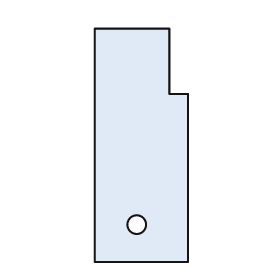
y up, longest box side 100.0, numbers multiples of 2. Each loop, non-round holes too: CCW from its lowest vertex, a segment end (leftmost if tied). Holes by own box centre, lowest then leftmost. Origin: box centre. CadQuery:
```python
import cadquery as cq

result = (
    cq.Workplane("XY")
    .moveTo(-20.0, -50.0)
    .lineTo(20.0, -50.0)
    .lineTo(20.0, 22.0)
    .lineTo(12.0, 22.0)
    .lineTo(12.0, 50.0)
    .lineTo(-20.0, 50.0)
    .close()
    .moveTo(-2.0, -34.0)
    .circle(4.0)
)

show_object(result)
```